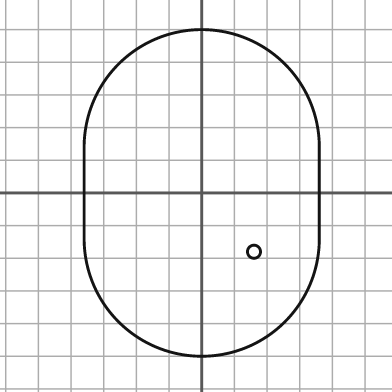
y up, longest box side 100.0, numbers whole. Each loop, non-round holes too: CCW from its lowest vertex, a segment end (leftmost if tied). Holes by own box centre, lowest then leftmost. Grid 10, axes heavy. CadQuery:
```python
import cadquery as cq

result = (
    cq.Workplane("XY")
    .moveTo(-36.0, -14.0)
    .threePointArc((0.0, -50.0), (36.0, -14.0))
    .lineTo(36.0, 14.0)
    .threePointArc((0.0, 50.0), (-36.0, 14.0))
    .close()
    .moveTo(16.0, -18.0)
    .circle(2.0)
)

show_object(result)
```